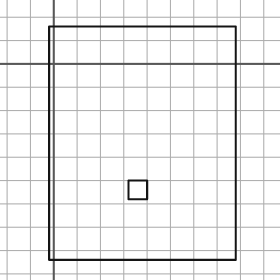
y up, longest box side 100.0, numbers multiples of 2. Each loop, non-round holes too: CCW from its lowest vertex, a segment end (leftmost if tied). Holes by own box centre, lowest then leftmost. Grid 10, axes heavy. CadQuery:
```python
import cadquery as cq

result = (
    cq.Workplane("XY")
    .moveTo(-2.0, -84.0)
    .lineTo(78.0, -84.0)
    .lineTo(78.0, 16.0)
    .lineTo(-2.0, 16.0)
    .close()
    .moveTo(32.0, -58.0)
    .lineTo(40.0, -58.0)
    .lineTo(40.0, -50.0)
    .lineTo(32.0, -50.0)
    .close()
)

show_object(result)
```